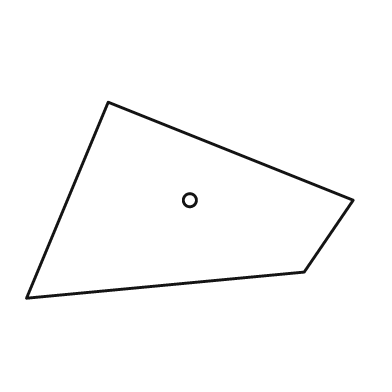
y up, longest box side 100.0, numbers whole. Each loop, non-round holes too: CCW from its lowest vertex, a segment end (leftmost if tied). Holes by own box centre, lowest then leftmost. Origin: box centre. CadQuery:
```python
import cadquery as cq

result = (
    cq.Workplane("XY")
    .moveTo(-50.0, -30.0)
    .lineTo(35.0, -22.0)
    .lineTo(50.0, 0.0)
    .lineTo(-25.0, 30.0)
    .close()
    .moveTo(0.0, 0.0)
    .circle(2.0)
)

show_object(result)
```